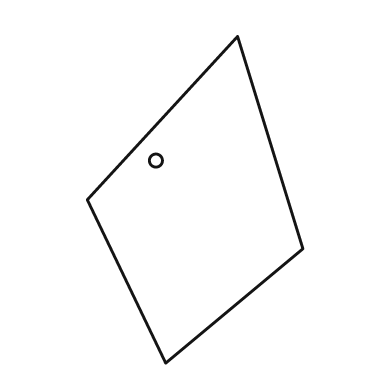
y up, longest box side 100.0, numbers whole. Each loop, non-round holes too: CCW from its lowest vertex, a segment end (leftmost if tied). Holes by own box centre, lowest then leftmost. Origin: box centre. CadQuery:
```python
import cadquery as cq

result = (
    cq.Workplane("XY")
    .moveTo(-9.0, -50.0)
    .lineTo(33.0, -15.0)
    .lineTo(13.0, 50.0)
    .lineTo(-33.0, 0.0)
    .close()
    .moveTo(-12.0, 12.0)
    .circle(2.0)
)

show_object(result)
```